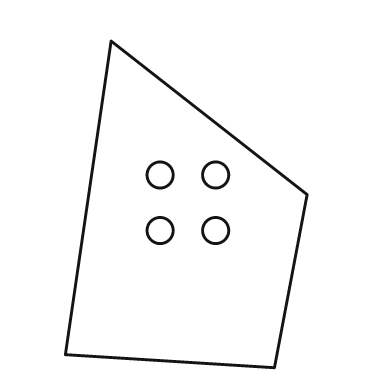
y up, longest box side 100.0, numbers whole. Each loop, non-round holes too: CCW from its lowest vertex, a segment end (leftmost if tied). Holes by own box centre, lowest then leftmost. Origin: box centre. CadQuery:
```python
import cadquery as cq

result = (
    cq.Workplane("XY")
    .moveTo(27.0, -50.0)
    .lineTo(37.0, 3.0)
    .lineTo(-23.0, 50.0)
    .lineTo(-37.0, -46.0)
    .close()
    .moveTo(-8.0, -8.0)
    .circle(4.0)
    .moveTo(9.0, -8.0)
    .circle(4.0)
    .moveTo(-8.0, 9.0)
    .circle(4.0)
    .moveTo(9.0, 9.0)
    .circle(4.0)
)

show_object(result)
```